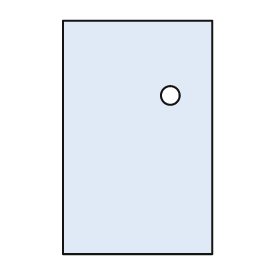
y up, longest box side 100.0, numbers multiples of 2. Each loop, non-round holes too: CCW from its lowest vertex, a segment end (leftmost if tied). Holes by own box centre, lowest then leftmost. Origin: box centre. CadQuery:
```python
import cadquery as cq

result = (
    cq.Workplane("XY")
    .moveTo(-32.0, -50.0)
    .lineTo(32.0, -50.0)
    .lineTo(32.0, 50.0)
    .lineTo(-32.0, 50.0)
    .close()
    .moveTo(14.0, 18.0)
    .circle(4.0)
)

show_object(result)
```